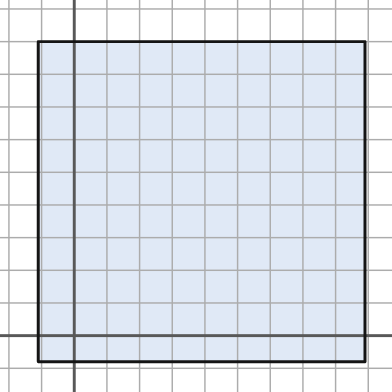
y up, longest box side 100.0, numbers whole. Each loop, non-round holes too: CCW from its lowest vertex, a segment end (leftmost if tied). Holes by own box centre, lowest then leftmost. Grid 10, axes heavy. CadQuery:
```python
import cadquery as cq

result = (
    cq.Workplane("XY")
    .moveTo(-11.0, -8.0)
    .lineTo(89.0, -8.0)
    .lineTo(89.0, 90.0)
    .lineTo(-11.0, 90.0)
    .close()
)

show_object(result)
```